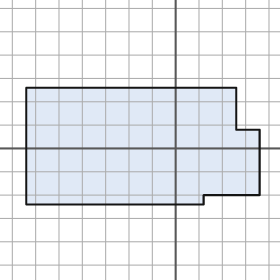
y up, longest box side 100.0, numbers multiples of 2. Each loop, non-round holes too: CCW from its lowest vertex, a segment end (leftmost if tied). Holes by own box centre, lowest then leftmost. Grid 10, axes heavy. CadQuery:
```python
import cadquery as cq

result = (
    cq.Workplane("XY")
    .moveTo(-64.0, -24.0)
    .lineTo(12.0, -24.0)
    .lineTo(12.0, -20.0)
    .lineTo(36.0, -20.0)
    .lineTo(36.0, 8.0)
    .lineTo(26.0, 8.0)
    .lineTo(26.0, 26.0)
    .lineTo(-64.0, 26.0)
    .close()
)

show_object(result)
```